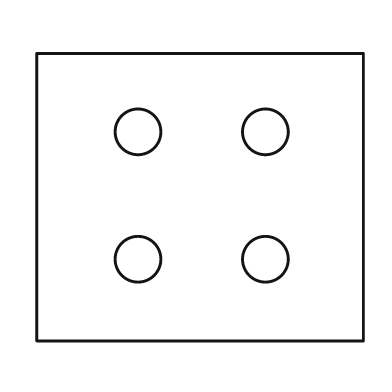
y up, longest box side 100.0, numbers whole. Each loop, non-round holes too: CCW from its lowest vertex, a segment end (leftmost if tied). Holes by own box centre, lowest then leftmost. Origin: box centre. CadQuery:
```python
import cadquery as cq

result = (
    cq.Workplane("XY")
    .moveTo(-50.0, -44.0)
    .lineTo(50.0, -44.0)
    .lineTo(50.0, 44.0)
    .lineTo(-50.0, 44.0)
    .close()
    .moveTo(-19.0, -19.0)
    .circle(7.0)
    .moveTo(20.0, -19.0)
    .circle(7.0)
    .moveTo(-19.0, 20.0)
    .circle(7.0)
    .moveTo(20.0, 20.0)
    .circle(7.0)
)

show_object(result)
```